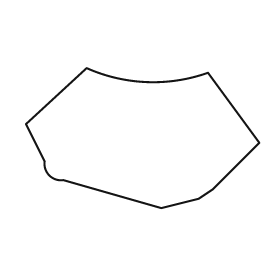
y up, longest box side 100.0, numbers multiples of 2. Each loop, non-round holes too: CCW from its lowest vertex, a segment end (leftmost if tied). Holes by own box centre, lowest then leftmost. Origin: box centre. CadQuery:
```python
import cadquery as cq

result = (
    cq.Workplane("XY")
    .moveTo(8.0, -30.0)
    .lineTo(24.0, -26.0)
    .lineTo(30.0, -22.0)
    .lineTo(50.0, -2.0)
    .lineTo(28.0, 28.0)
    .threePointArc((2.0, 24.0), (-24.0, 30.0))
    .lineTo(-50.0, 6.0)
    .lineTo(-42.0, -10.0)
    .threePointArc((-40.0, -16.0), (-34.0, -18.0))
    .close()
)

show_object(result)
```